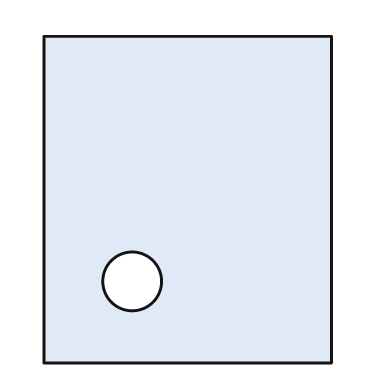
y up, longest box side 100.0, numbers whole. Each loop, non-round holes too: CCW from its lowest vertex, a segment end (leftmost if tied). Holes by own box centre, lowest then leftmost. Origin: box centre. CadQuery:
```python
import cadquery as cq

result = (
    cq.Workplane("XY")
    .moveTo(-44.0, -50.0)
    .lineTo(44.0, -50.0)
    .lineTo(44.0, 50.0)
    .lineTo(-44.0, 50.0)
    .close()
    .moveTo(-17.0, -25.0)
    .circle(9.0)
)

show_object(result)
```